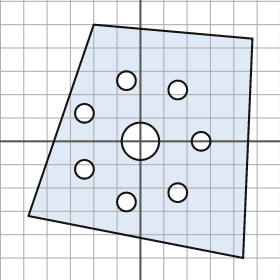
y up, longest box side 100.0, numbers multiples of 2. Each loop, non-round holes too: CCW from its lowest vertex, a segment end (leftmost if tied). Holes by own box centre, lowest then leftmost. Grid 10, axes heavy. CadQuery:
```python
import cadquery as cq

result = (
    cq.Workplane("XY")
    .moveTo(44.0, -50.0)
    .lineTo(48.0, 44.0)
    .lineTo(-20.0, 50.0)
    .lineTo(-48.0, -32.0)
    .close()
    .moveTo(-6.0, -26.0)
    .circle(4.0)
    .moveTo(16.0, -22.0)
    .circle(4.0)
    .moveTo(-24.0, -12.0)
    .circle(4.0)
    .moveTo(0.0, 0.0)
    .circle(8.0)
    .moveTo(26.0, 0.0)
    .circle(4.0)
    .moveTo(-24.0, 12.0)
    .circle(4.0)
    .moveTo(16.0, 22.0)
    .circle(4.0)
    .moveTo(-6.0, 26.0)
    .circle(4.0)
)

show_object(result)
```